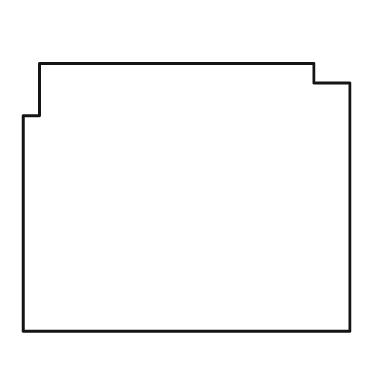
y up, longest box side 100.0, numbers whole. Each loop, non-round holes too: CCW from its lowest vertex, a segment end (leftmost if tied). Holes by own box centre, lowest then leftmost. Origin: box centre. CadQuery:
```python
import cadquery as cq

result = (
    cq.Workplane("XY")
    .moveTo(-50.0, -41.0)
    .lineTo(50.0, -41.0)
    .lineTo(50.0, 35.0)
    .lineTo(39.0, 35.0)
    .lineTo(39.0, 41.0)
    .lineTo(-45.0, 41.0)
    .lineTo(-45.0, 25.0)
    .lineTo(-50.0, 25.0)
    .close()
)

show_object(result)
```